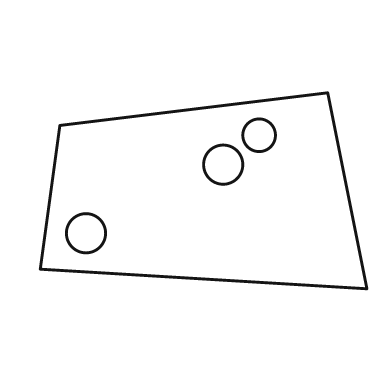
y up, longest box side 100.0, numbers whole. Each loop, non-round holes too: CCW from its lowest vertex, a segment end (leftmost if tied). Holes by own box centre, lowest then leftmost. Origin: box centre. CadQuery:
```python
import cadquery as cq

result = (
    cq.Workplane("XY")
    .moveTo(50.0, -30.0)
    .lineTo(38.0, 30.0)
    .lineTo(-44.0, 20.0)
    .lineTo(-50.0, -24.0)
    .close()
    .moveTo(-36.0, -13.0)
    .circle(6.0)
    .moveTo(6.0, 8.0)
    .circle(6.0)
    .moveTo(17.0, 17.0)
    .circle(5.0)
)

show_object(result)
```